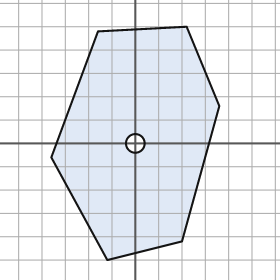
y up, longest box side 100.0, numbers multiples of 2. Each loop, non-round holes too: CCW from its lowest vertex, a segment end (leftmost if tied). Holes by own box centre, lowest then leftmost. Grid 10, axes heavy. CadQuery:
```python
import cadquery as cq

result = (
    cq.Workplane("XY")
    .moveTo(-12.0, -50.0)
    .lineTo(20.0, -42.0)
    .lineTo(36.0, 16.0)
    .lineTo(22.0, 50.0)
    .lineTo(-16.0, 48.0)
    .lineTo(-36.0, -6.0)
    .close()
    .moveTo(0.0, 0.0)
    .circle(4.0)
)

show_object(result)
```